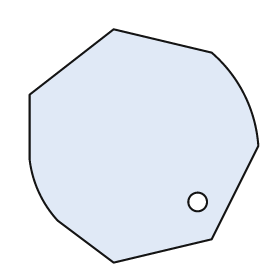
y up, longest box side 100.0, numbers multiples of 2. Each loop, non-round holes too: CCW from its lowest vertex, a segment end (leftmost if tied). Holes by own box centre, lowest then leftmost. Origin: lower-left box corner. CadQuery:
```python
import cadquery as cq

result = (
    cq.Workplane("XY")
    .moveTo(36.0, 0.0)
    .lineTo(78.0, 10.0)
    .lineTo(98.0, 50.0)
    .threePointArc((92.0, 72.0), (78.0, 90.0))
    .lineTo(36.0, 100.0)
    .lineTo(0.0, 72.0)
    .lineTo(0.0, 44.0)
    .threePointArc((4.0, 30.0), (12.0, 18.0))
    .close()
    .moveTo(72.0, 26.0)
    .circle(4.0)
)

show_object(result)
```